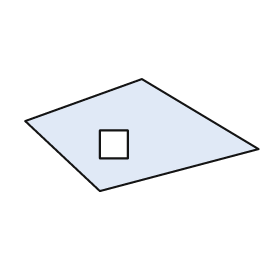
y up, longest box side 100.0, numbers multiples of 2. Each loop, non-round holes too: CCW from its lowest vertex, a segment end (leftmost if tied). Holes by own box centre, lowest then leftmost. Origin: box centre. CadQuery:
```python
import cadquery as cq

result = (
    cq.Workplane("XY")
    .moveTo(-18.0, -24.0)
    .lineTo(50.0, -6.0)
    .lineTo(0.0, 24.0)
    .lineTo(-50.0, 6.0)
    .close()
    .moveTo(-18.0, -10.0)
    .lineTo(-6.0, -10.0)
    .lineTo(-6.0, 2.0)
    .lineTo(-18.0, 2.0)
    .close()
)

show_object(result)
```